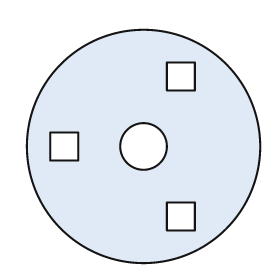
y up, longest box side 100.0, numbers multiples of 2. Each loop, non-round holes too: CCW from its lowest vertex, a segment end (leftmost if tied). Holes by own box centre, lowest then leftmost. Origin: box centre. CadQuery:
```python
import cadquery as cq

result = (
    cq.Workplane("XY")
    .moveTo(0.0, 0.0)
    .circle(50.0)
    .moveTo(10.0, -36.0)
    .lineTo(22.0, -36.0)
    .lineTo(22.0, -24.0)
    .lineTo(10.0, -24.0)
    .close()
    .moveTo(-40.0, -6.0)
    .lineTo(-28.0, -6.0)
    .lineTo(-28.0, 6.0)
    .lineTo(-40.0, 6.0)
    .close()
    .moveTo(0.0, 0.0)
    .circle(10.0)
    .moveTo(10.0, 24.0)
    .lineTo(22.0, 24.0)
    .lineTo(22.0, 36.0)
    .lineTo(10.0, 36.0)
    .close()
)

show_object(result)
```